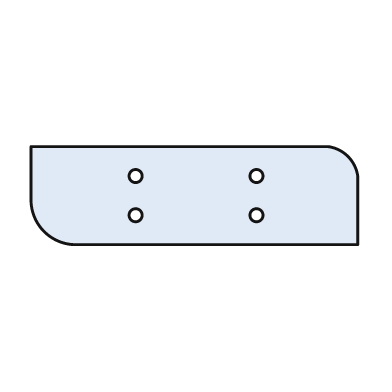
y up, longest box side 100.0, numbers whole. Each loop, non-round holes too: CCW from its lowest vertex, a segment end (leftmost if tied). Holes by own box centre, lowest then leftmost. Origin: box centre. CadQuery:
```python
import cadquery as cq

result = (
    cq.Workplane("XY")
    .moveTo(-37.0, -15.0)
    .lineTo(50.0, -15.0)
    .lineTo(50.0, 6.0)
    .threePointArc((47.0, 12.0), (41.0, 15.0))
    .lineTo(-50.0, 15.0)
    .lineTo(-50.0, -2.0)
    .threePointArc((-46.0, -11.0), (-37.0, -15.0))
    .close()
    .moveTo(-18.0, -6.0)
    .circle(2.0)
    .moveTo(19.0, -6.0)
    .circle(2.0)
    .moveTo(-18.0, 6.0)
    .circle(2.0)
    .moveTo(19.0, 6.0)
    .circle(2.0)
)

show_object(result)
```